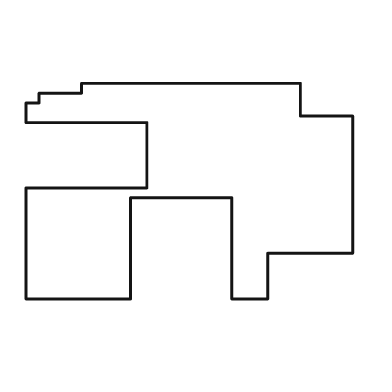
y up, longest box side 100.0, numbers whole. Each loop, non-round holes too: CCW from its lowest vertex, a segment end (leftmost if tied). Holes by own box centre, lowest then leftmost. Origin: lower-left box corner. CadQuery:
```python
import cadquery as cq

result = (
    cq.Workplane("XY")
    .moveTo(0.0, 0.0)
    .lineTo(32.0, 0.0)
    .lineTo(32.0, 31.0)
    .lineTo(63.0, 31.0)
    .lineTo(63.0, 0.0)
    .lineTo(74.0, 0.0)
    .lineTo(74.0, 14.0)
    .lineTo(100.0, 14.0)
    .lineTo(100.0, 56.0)
    .lineTo(84.0, 56.0)
    .lineTo(84.0, 66.0)
    .lineTo(17.0, 66.0)
    .lineTo(17.0, 63.0)
    .lineTo(4.0, 63.0)
    .lineTo(4.0, 60.0)
    .lineTo(0.0, 60.0)
    .lineTo(0.0, 54.0)
    .lineTo(37.0, 54.0)
    .lineTo(37.0, 34.0)
    .lineTo(0.0, 34.0)
    .close()
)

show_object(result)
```